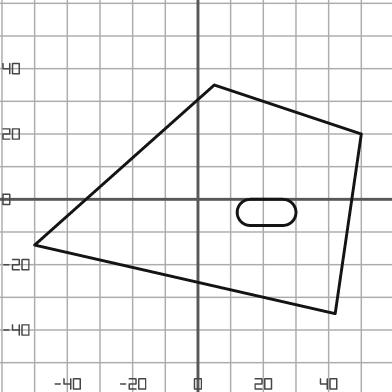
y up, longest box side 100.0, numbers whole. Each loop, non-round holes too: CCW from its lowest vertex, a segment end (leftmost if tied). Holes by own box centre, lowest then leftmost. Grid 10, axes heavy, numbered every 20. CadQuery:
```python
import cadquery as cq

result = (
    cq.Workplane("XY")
    .moveTo(42.0, -35.0)
    .lineTo(50.0, 20.0)
    .lineTo(5.0, 35.0)
    .lineTo(-50.0, -14.0)
    .close()
    .moveTo(16.0, -8.0)
    .lineTo(26.0, -8.0)
    .threePointArc((30.0, -4.0), (26.0, 0.0))
    .lineTo(16.0, 0.0)
    .threePointArc((12.0, -4.0), (16.0, -8.0))
    .close()
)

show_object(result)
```